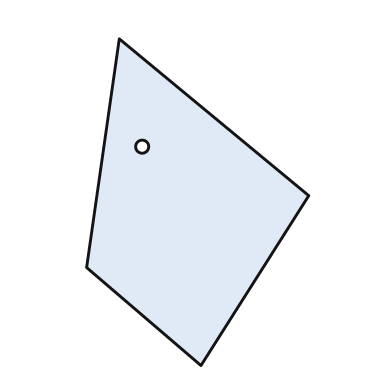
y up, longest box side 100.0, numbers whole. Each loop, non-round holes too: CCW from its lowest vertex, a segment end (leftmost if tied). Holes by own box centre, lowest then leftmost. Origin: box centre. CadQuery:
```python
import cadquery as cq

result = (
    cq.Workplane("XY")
    .moveTo(1.0, -50.0)
    .lineTo(34.0, 2.0)
    .lineTo(-24.0, 50.0)
    .lineTo(-34.0, -20.0)
    .close()
    .moveTo(-17.0, 17.0)
    .circle(2.0)
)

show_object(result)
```